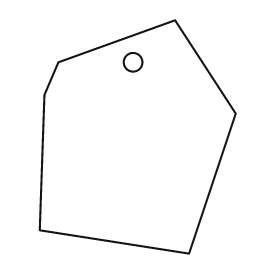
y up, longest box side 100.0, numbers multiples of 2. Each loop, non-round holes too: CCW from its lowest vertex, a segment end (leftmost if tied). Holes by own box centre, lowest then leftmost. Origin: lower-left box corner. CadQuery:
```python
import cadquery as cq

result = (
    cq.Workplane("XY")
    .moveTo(64.0, 0.0)
    .lineTo(84.0, 60.0)
    .lineTo(58.0, 100.0)
    .lineTo(8.0, 82.0)
    .lineTo(2.0, 68.0)
    .lineTo(0.0, 10.0)
    .close()
    .moveTo(40.0, 82.0)
    .circle(4.0)
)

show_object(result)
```